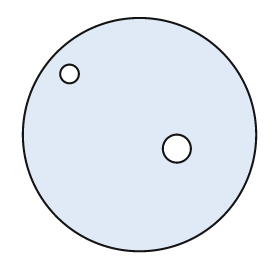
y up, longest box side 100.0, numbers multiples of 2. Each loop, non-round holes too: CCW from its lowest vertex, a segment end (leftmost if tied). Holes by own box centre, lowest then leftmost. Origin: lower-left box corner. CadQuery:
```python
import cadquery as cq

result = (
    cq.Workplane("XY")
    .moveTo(50.0, 50.0)
    .circle(50.0)
    .moveTo(66.0, 44.0)
    .circle(6.0)
    .moveTo(20.0, 76.0)
    .circle(4.0)
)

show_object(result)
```